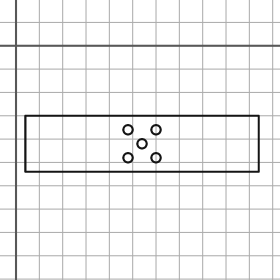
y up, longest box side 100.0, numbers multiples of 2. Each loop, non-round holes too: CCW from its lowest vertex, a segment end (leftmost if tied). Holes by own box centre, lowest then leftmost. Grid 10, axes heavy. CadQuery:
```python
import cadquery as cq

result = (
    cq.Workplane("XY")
    .moveTo(4.0, -54.0)
    .lineTo(104.0, -54.0)
    .lineTo(104.0, -30.0)
    .lineTo(4.0, -30.0)
    .close()
    .moveTo(48.0, -48.0)
    .circle(2.0)
    .moveTo(60.0, -48.0)
    .circle(2.0)
    .moveTo(54.0, -42.0)
    .circle(2.0)
    .moveTo(48.0, -36.0)
    .circle(2.0)
    .moveTo(60.0, -36.0)
    .circle(2.0)
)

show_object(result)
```